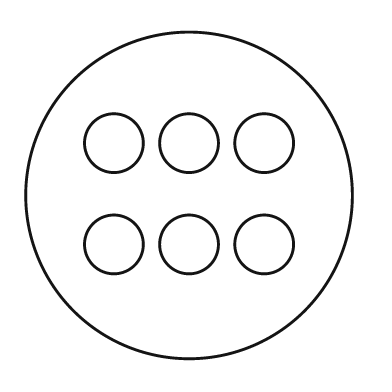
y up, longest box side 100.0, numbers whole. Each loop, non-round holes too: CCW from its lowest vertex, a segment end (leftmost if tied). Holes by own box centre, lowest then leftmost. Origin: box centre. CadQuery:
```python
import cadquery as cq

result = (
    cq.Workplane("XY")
    .moveTo(0.0, 0.0)
    .circle(50.0)
    .moveTo(-23.0, -15.0)
    .circle(9.0)
    .moveTo(0.0, -15.0)
    .circle(9.0)
    .moveTo(23.0, -15.0)
    .circle(9.0)
    .moveTo(-23.0, 16.0)
    .circle(9.0)
    .moveTo(0.0, 16.0)
    .circle(9.0)
    .moveTo(23.0, 16.0)
    .circle(9.0)
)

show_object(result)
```